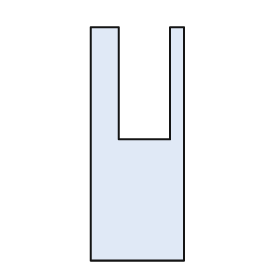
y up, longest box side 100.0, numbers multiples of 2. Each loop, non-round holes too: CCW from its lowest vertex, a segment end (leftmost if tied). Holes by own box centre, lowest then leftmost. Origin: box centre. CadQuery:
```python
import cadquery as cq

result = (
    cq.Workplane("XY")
    .moveTo(-20.0, -50.0)
    .lineTo(20.0, -50.0)
    .lineTo(20.0, 50.0)
    .lineTo(14.0, 50.0)
    .lineTo(14.0, 2.0)
    .lineTo(-8.0, 2.0)
    .lineTo(-8.0, 50.0)
    .lineTo(-20.0, 50.0)
    .close()
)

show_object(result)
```